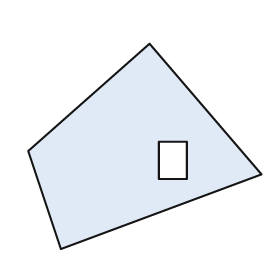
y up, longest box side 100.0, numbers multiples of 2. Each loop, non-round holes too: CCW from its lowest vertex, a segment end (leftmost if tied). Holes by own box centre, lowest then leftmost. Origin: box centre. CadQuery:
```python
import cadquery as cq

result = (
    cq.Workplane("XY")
    .moveTo(-36.0, -44.0)
    .lineTo(50.0, -12.0)
    .lineTo(2.0, 44.0)
    .lineTo(-50.0, -2.0)
    .close()
    .moveTo(6.0, -14.0)
    .lineTo(18.0, -14.0)
    .lineTo(18.0, 2.0)
    .lineTo(6.0, 2.0)
    .close()
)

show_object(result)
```